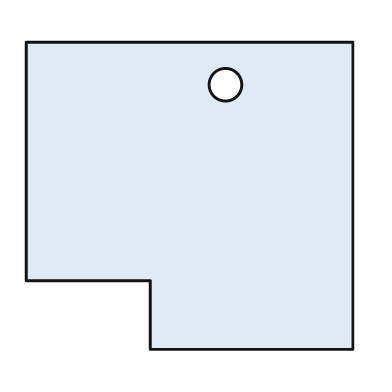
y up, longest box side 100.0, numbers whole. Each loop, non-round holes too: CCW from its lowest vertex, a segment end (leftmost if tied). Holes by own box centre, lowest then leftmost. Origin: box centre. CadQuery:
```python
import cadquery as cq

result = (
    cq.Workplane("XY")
    .moveTo(-12.0, -47.0)
    .lineTo(50.0, -47.0)
    .lineTo(50.0, 47.0)
    .lineTo(-50.0, 47.0)
    .lineTo(-50.0, -26.0)
    .lineTo(-12.0, -26.0)
    .close()
    .moveTo(11.0, 34.0)
    .circle(5.0)
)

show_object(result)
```